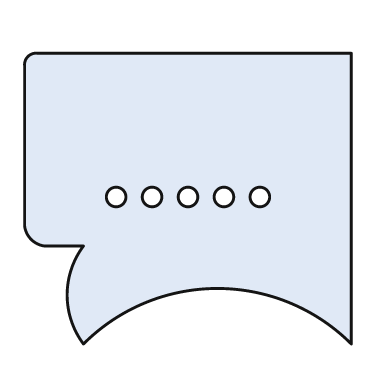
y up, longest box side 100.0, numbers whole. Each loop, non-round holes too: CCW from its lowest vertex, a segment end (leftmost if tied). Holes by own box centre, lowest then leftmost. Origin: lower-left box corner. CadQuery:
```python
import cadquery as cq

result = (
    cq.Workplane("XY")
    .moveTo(18.0, 0.0)
    .threePointArc((59.0, 17.0), (100.0, 0.0))
    .lineTo(100.0, 89.0)
    .lineTo(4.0, 89.0)
    .threePointArc((1.0, 88.0), (0.0, 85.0))
    .lineTo(0.0, 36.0)
    .threePointArc((2.0, 32.0), (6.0, 30.0))
    .lineTo(18.0, 30.0)
    .threePointArc((13.0, 15.0), (18.0, 0.0))
    .close()
    .moveTo(28.0, 45.0)
    .circle(3.0)
    .moveTo(39.0, 45.0)
    .circle(3.0)
    .moveTo(50.0, 45.0)
    .circle(3.0)
    .moveTo(61.0, 45.0)
    .circle(3.0)
    .moveTo(72.0, 45.0)
    .circle(3.0)
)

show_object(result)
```